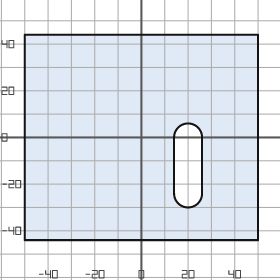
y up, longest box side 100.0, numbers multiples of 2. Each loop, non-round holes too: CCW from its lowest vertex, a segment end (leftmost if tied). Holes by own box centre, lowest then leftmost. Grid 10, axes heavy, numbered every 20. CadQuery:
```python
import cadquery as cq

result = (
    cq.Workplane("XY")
    .moveTo(-50.0, -44.0)
    .lineTo(50.0, -44.0)
    .lineTo(50.0, 44.0)
    .lineTo(-50.0, 44.0)
    .close()
    .moveTo(14.0, -24.0)
    .threePointArc((20.0, -30.0), (26.0, -24.0))
    .lineTo(26.0, 0.0)
    .threePointArc((20.0, 6.0), (14.0, 0.0))
    .close()
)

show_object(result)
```